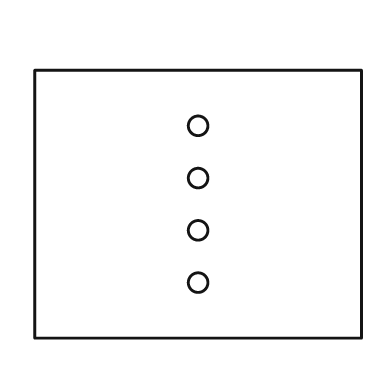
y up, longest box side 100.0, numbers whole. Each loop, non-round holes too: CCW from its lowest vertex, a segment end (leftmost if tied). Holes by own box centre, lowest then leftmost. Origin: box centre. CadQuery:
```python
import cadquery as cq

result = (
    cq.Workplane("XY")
    .moveTo(-50.0, -41.0)
    .lineTo(50.0, -41.0)
    .lineTo(50.0, 41.0)
    .lineTo(-50.0, 41.0)
    .close()
    .moveTo(0.0, -24.0)
    .circle(3.0)
    .moveTo(0.0, -8.0)
    .circle(3.0)
    .moveTo(0.0, 8.0)
    .circle(3.0)
    .moveTo(0.0, 24.0)
    .circle(3.0)
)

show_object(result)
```